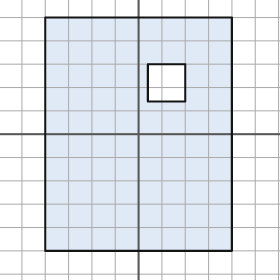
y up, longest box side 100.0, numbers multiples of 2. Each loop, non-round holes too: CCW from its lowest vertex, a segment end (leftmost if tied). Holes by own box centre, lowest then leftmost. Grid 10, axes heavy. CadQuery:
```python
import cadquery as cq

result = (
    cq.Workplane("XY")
    .moveTo(-40.0, -50.0)
    .lineTo(40.0, -50.0)
    .lineTo(40.0, 50.0)
    .lineTo(-40.0, 50.0)
    .close()
    .moveTo(4.0, 14.0)
    .lineTo(20.0, 14.0)
    .lineTo(20.0, 30.0)
    .lineTo(4.0, 30.0)
    .close()
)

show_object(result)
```